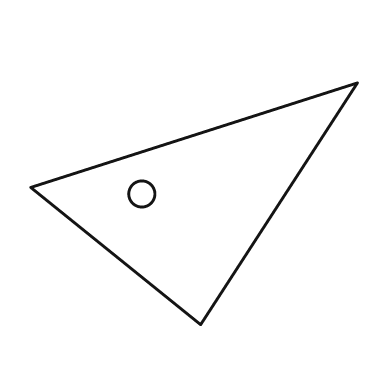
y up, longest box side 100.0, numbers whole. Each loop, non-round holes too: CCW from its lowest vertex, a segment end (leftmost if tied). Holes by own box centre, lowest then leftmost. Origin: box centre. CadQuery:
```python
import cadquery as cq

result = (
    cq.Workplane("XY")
    .moveTo(2.0, -37.0)
    .lineTo(50.0, 37.0)
    .lineTo(-50.0, 5.0)
    .close()
    .moveTo(-16.0, 3.0)
    .circle(4.0)
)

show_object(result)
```